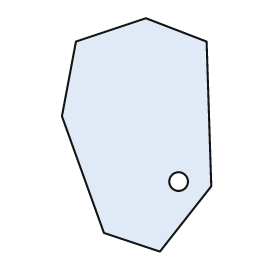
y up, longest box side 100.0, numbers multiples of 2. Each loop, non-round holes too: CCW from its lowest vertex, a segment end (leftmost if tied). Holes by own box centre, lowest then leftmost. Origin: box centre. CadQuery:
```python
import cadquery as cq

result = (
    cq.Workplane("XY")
    .moveTo(10.0, -50.0)
    .lineTo(32.0, -22.0)
    .lineTo(30.0, 40.0)
    .lineTo(4.0, 50.0)
    .lineTo(-26.0, 40.0)
    .lineTo(-32.0, 8.0)
    .lineTo(-14.0, -42.0)
    .close()
    .moveTo(18.0, -20.0)
    .circle(4.0)
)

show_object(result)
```